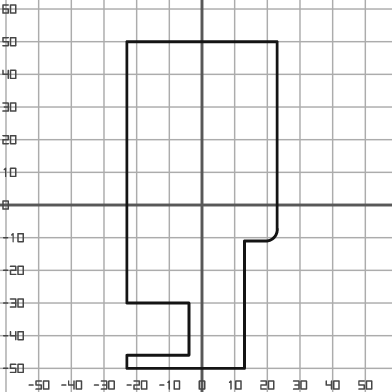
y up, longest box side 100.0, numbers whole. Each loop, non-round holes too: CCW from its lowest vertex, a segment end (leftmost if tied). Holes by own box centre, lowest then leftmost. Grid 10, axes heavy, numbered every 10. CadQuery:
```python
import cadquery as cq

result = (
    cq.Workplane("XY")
    .moveTo(-23.0, -50.0)
    .lineTo(13.0, -50.0)
    .lineTo(13.0, -11.0)
    .lineTo(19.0, -11.0)
    .threePointArc((22.0, -10.0), (23.0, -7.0))
    .lineTo(23.0, 50.0)
    .lineTo(-23.0, 50.0)
    .lineTo(-23.0, -30.0)
    .lineTo(-4.0, -30.0)
    .lineTo(-4.0, -46.0)
    .lineTo(-23.0, -46.0)
    .close()
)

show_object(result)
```